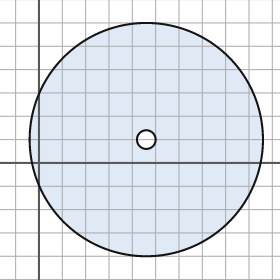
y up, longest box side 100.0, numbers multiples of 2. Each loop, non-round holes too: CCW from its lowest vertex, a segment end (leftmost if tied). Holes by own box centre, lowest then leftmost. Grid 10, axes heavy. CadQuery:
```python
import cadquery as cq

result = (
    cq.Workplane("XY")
    .moveTo(46.0, 10.0)
    .circle(50.0)
    .moveTo(46.0, 10.0)
    .circle(4.0)
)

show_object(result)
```